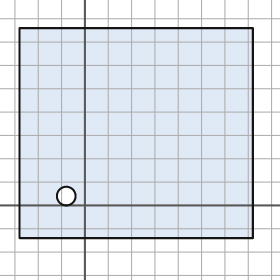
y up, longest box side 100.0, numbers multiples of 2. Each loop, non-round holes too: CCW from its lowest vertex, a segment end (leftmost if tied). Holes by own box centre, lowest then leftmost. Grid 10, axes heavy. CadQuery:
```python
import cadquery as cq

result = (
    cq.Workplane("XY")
    .moveTo(-28.0, -14.0)
    .lineTo(72.0, -14.0)
    .lineTo(72.0, 76.0)
    .lineTo(-28.0, 76.0)
    .close()
    .moveTo(-8.0, 4.0)
    .circle(4.0)
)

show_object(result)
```